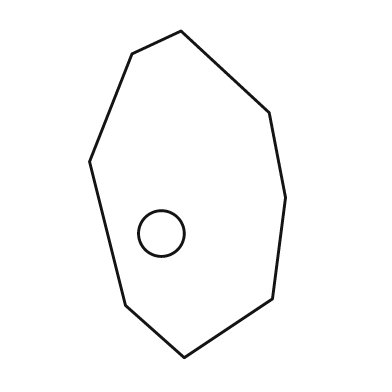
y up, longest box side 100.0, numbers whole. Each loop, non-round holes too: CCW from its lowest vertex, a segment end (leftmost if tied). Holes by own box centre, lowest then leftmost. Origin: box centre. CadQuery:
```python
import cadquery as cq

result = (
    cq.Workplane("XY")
    .moveTo(-1.0, -50.0)
    .lineTo(26.0, -32.0)
    .lineTo(30.0, -1.0)
    .lineTo(25.0, 25.0)
    .lineTo(-2.0, 50.0)
    .lineTo(-17.0, 43.0)
    .lineTo(-30.0, 10.0)
    .lineTo(-19.0, -34.0)
    .close()
    .moveTo(-8.0, -12.0)
    .circle(7.0)
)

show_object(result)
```